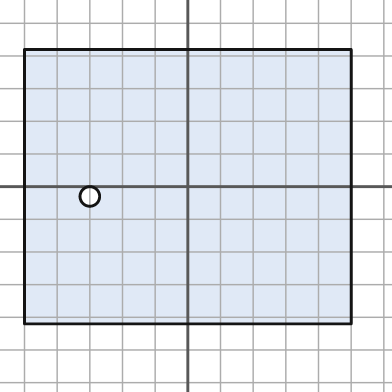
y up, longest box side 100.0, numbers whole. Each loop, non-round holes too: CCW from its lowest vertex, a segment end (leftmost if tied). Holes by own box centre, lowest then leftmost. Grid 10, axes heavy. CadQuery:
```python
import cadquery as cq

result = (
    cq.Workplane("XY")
    .moveTo(-50.0, -42.0)
    .lineTo(50.0, -42.0)
    .lineTo(50.0, 42.0)
    .lineTo(-50.0, 42.0)
    .close()
    .moveTo(-30.0, -3.0)
    .circle(3.0)
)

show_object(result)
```